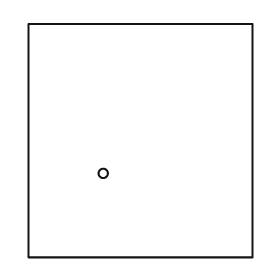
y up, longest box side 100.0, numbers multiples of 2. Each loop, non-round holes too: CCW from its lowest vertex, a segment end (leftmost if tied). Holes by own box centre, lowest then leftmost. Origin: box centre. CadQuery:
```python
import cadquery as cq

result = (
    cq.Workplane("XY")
    .moveTo(-48.0, -50.0)
    .lineTo(48.0, -50.0)
    .lineTo(48.0, 50.0)
    .lineTo(-48.0, 50.0)
    .close()
    .moveTo(-16.0, -14.0)
    .circle(2.0)
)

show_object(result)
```